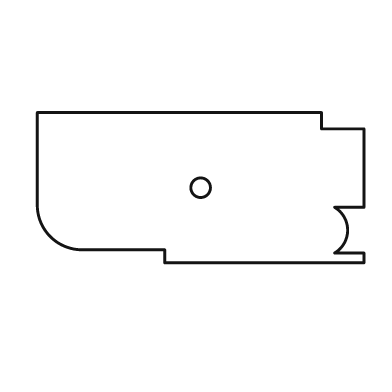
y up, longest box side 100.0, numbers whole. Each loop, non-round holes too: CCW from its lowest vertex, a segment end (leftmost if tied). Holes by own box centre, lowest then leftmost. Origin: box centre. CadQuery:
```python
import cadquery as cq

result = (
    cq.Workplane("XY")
    .moveTo(-11.0, -23.0)
    .lineTo(50.0, -23.0)
    .lineTo(50.0, -20.0)
    .lineTo(41.0, -20.0)
    .threePointArc((45.0, -13.0), (41.0, -6.0))
    .lineTo(50.0, -6.0)
    .lineTo(50.0, 18.0)
    .lineTo(37.0, 18.0)
    .lineTo(37.0, 23.0)
    .lineTo(-50.0, 23.0)
    .lineTo(-50.0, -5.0)
    .threePointArc((-46.0, -15.0), (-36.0, -19.0))
    .lineTo(-11.0, -19.0)
    .close()
    .moveTo(0.0, 0.0)
    .circle(3.0)
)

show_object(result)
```